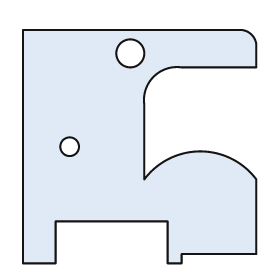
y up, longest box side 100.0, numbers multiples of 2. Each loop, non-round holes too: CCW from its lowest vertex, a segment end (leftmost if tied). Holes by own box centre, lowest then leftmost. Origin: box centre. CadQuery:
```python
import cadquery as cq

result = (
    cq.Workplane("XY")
    .moveTo(-50.0, -50.0)
    .lineTo(-36.0, -50.0)
    .lineTo(-36.0, -32.0)
    .lineTo(12.0, -32.0)
    .lineTo(12.0, -50.0)
    .lineTo(18.0, -50.0)
    .lineTo(18.0, -46.0)
    .lineTo(50.0, -46.0)
    .lineTo(50.0, -14.0)
    .threePointArc((26.0, -2.0), (2.0, -14.0))
    .lineTo(2.0, 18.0)
    .threePointArc((6.0, 30.0), (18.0, 34.0))
    .lineTo(50.0, 34.0)
    .lineTo(50.0, 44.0)
    .threePointArc((48.0, 48.0), (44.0, 50.0))
    .lineTo(-50.0, 50.0)
    .close()
    .moveTo(-30.0, 0.0)
    .circle(4.0)
    .moveTo(-4.0, 40.0)
    .circle(6.0)
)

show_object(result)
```